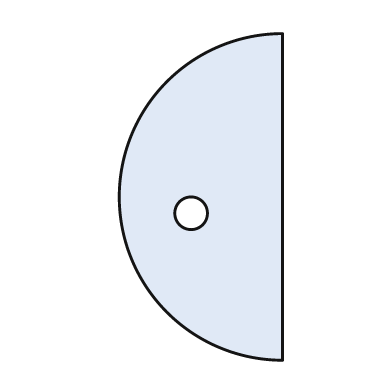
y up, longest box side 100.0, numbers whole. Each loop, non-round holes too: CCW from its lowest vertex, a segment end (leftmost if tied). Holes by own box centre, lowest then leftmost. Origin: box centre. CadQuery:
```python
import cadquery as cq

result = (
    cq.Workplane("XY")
    .moveTo(25.0, -50.0)
    .lineTo(25.0, 50.0)
    .threePointArc((-25.0, 0.0), (25.0, -50.0))
    .close()
    .moveTo(-3.0, -5.0)
    .circle(5.0)
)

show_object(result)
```